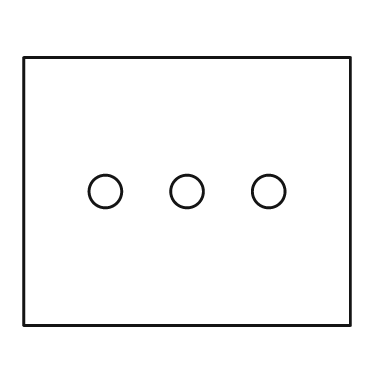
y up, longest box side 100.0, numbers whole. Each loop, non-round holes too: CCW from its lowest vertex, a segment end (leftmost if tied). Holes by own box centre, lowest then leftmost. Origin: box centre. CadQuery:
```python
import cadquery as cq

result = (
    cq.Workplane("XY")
    .moveTo(-50.0, -41.0)
    .lineTo(50.0, -41.0)
    .lineTo(50.0, 41.0)
    .lineTo(-50.0, 41.0)
    .close()
    .moveTo(-25.0, 0.0)
    .circle(5.0)
    .moveTo(0.0, 0.0)
    .circle(5.0)
    .moveTo(25.0, 0.0)
    .circle(5.0)
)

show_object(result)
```